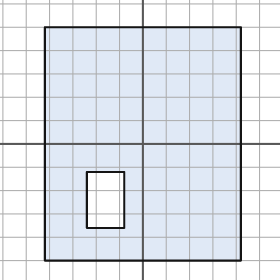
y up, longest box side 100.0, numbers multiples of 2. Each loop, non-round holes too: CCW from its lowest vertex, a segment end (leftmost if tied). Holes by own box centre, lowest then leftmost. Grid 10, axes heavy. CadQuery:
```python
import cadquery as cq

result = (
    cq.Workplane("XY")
    .moveTo(-42.0, -50.0)
    .lineTo(42.0, -50.0)
    .lineTo(42.0, 50.0)
    .lineTo(-42.0, 50.0)
    .close()
    .moveTo(-24.0, -36.0)
    .lineTo(-8.0, -36.0)
    .lineTo(-8.0, -12.0)
    .lineTo(-24.0, -12.0)
    .close()
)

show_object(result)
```